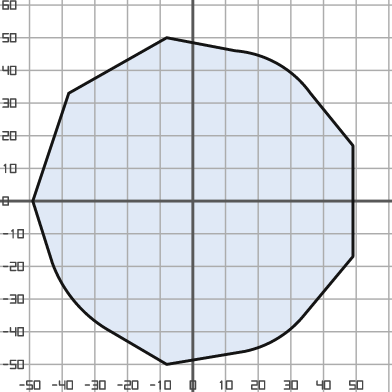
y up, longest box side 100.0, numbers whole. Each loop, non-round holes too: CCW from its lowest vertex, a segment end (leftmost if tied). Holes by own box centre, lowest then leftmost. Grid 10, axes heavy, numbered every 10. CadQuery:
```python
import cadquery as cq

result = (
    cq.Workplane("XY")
    .moveTo(-8.0, -50.0)
    .lineTo(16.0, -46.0)
    .threePointArc((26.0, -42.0), (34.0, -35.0))
    .lineTo(49.0, -17.0)
    .lineTo(49.0, 17.0)
    .lineTo(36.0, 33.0)
    .threePointArc((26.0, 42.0), (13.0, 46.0))
    .lineTo(-8.0, 50.0)
    .lineTo(-38.0, 33.0)
    .lineTo(-49.0, 0.0)
    .lineTo(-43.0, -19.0)
    .threePointArc((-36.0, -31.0), (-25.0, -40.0))
    .close()
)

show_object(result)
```